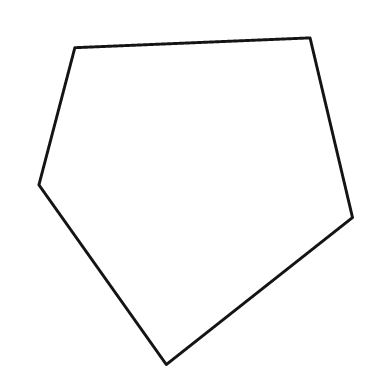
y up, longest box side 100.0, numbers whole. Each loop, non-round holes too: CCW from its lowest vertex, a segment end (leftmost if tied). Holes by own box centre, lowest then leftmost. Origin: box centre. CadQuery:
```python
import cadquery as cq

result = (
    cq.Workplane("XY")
    .moveTo(-9.0, -50.0)
    .lineTo(48.0, -5.0)
    .lineTo(35.0, 50.0)
    .lineTo(-37.0, 47.0)
    .lineTo(-48.0, 5.0)
    .close()
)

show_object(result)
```